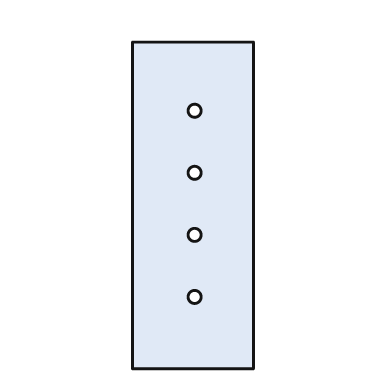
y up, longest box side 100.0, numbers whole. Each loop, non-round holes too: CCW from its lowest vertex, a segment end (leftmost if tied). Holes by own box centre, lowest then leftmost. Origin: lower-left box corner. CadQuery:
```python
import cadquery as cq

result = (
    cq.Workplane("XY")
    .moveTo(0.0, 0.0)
    .lineTo(37.0, 0.0)
    .lineTo(37.0, 100.0)
    .lineTo(0.0, 100.0)
    .close()
    .moveTo(19.0, 22.0)
    .circle(2.0)
    .moveTo(19.0, 41.0)
    .circle(2.0)
    .moveTo(19.0, 60.0)
    .circle(2.0)
    .moveTo(19.0, 79.0)
    .circle(2.0)
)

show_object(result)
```